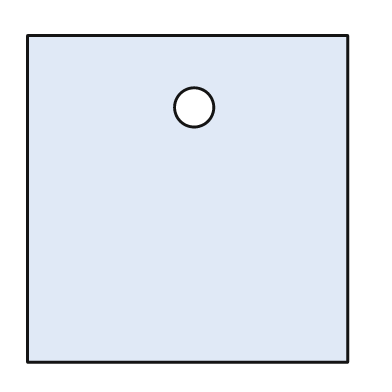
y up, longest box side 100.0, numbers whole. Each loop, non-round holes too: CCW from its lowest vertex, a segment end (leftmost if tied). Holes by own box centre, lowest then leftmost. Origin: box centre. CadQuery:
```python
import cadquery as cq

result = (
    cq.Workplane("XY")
    .moveTo(-49.0, -50.0)
    .lineTo(49.0, -50.0)
    .lineTo(49.0, 50.0)
    .lineTo(-49.0, 50.0)
    .close()
    .moveTo(2.0, 28.0)
    .circle(6.0)
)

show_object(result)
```